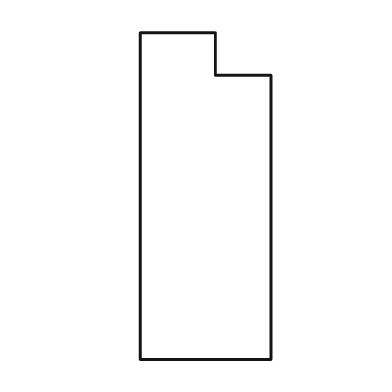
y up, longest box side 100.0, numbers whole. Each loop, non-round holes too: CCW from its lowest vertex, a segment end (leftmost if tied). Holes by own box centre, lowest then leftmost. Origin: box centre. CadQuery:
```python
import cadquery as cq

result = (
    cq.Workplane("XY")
    .moveTo(-20.0, -50.0)
    .lineTo(20.0, -50.0)
    .lineTo(20.0, 37.0)
    .lineTo(3.0, 37.0)
    .lineTo(3.0, 50.0)
    .lineTo(-20.0, 50.0)
    .close()
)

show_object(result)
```